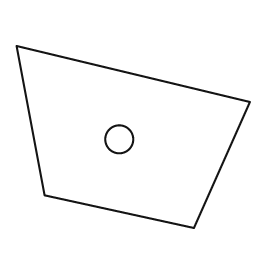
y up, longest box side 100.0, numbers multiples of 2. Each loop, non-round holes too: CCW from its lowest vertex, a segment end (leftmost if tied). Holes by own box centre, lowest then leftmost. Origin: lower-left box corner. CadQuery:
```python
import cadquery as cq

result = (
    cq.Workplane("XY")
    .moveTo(76.0, 0.0)
    .lineTo(100.0, 54.0)
    .lineTo(0.0, 78.0)
    .lineTo(12.0, 14.0)
    .close()
    .moveTo(44.0, 38.0)
    .circle(6.0)
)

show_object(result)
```